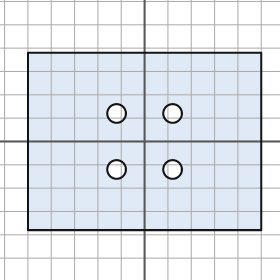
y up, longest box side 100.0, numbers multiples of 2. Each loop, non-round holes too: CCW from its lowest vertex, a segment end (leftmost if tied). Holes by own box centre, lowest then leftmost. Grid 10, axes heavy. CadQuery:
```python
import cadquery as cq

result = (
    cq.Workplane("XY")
    .moveTo(-50.0, -38.0)
    .lineTo(50.0, -38.0)
    .lineTo(50.0, 38.0)
    .lineTo(-50.0, 38.0)
    .close()
    .moveTo(-12.0, -12.0)
    .circle(4.0)
    .moveTo(12.0, -12.0)
    .circle(4.0)
    .moveTo(-12.0, 12.0)
    .circle(4.0)
    .moveTo(12.0, 12.0)
    .circle(4.0)
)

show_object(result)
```